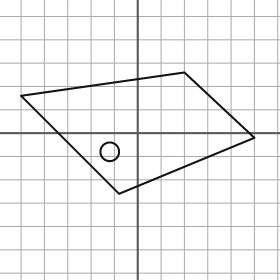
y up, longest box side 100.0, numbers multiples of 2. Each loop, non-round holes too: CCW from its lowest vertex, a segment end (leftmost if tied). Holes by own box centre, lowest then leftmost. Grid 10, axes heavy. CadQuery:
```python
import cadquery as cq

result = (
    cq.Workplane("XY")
    .moveTo(-8.0, -26.0)
    .lineTo(50.0, -2.0)
    .lineTo(20.0, 26.0)
    .lineTo(-50.0, 16.0)
    .close()
    .moveTo(-12.0, -8.0)
    .circle(4.0)
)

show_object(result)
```